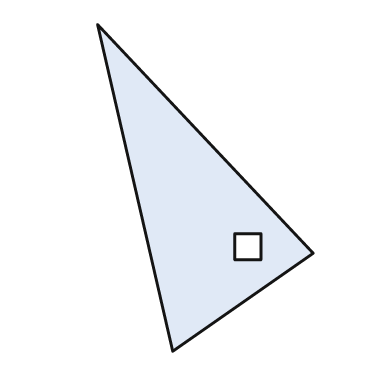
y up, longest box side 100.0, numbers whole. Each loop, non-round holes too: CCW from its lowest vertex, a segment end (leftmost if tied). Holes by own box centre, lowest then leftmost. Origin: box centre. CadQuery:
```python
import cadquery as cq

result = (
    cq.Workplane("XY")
    .moveTo(-10.0, -50.0)
    .lineTo(33.0, -20.0)
    .lineTo(-33.0, 50.0)
    .close()
    .moveTo(9.0, -22.0)
    .lineTo(17.0, -22.0)
    .lineTo(17.0, -14.0)
    .lineTo(9.0, -14.0)
    .close()
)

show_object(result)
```